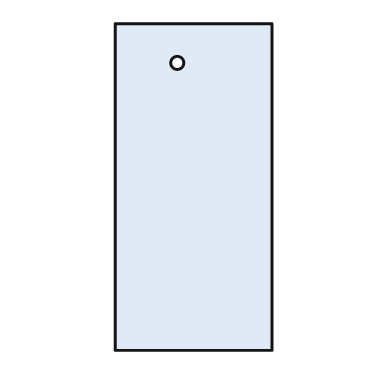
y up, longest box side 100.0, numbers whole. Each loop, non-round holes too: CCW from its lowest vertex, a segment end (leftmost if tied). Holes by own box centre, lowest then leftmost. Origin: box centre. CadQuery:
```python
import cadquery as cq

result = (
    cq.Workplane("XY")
    .moveTo(-24.0, -50.0)
    .lineTo(24.0, -50.0)
    .lineTo(24.0, 50.0)
    .lineTo(-24.0, 50.0)
    .close()
    .moveTo(-5.0, 38.0)
    .circle(2.0)
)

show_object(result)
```